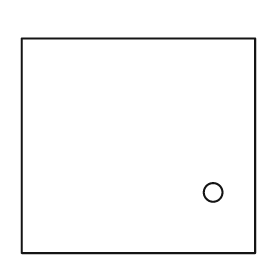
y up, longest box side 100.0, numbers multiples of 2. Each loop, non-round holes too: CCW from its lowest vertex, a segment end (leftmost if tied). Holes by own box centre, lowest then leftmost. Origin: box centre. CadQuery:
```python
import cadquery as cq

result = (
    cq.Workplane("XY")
    .moveTo(-50.0, -46.0)
    .lineTo(50.0, -46.0)
    .lineTo(50.0, 46.0)
    .lineTo(-50.0, 46.0)
    .close()
    .moveTo(32.0, -20.0)
    .circle(4.0)
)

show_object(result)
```